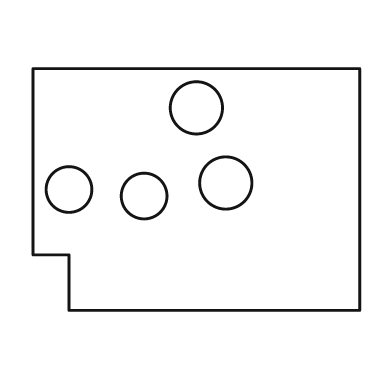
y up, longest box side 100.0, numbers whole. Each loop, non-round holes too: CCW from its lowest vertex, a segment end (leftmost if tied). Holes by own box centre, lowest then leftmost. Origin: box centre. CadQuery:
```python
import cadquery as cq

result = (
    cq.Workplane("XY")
    .moveTo(-39.0, -37.0)
    .lineTo(50.0, -37.0)
    .lineTo(50.0, 37.0)
    .lineTo(-50.0, 37.0)
    .lineTo(-50.0, -20.0)
    .lineTo(-39.0, -20.0)
    .close()
    .moveTo(-16.0, -2.0)
    .circle(7.0)
    .moveTo(-39.0, 0.0)
    .circle(7.0)
    .moveTo(9.0, 2.0)
    .circle(8.0)
    .moveTo(0.0, 25.0)
    .circle(8.0)
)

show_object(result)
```